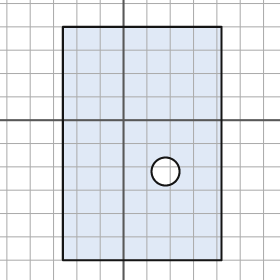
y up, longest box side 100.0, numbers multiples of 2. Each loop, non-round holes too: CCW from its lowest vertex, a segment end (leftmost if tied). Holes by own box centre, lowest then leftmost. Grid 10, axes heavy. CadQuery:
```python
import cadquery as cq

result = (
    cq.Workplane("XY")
    .moveTo(-26.0, -60.0)
    .lineTo(42.0, -60.0)
    .lineTo(42.0, 40.0)
    .lineTo(-26.0, 40.0)
    .close()
    .moveTo(18.0, -22.0)
    .circle(6.0)
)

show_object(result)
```